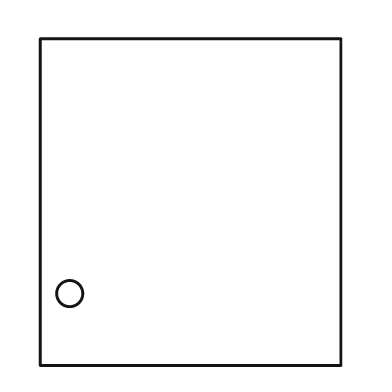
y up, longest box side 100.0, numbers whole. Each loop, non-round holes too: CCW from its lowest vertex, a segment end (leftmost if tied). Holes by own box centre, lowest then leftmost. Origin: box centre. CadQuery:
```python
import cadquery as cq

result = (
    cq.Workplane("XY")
    .moveTo(-46.0, -50.0)
    .lineTo(46.0, -50.0)
    .lineTo(46.0, 50.0)
    .lineTo(-46.0, 50.0)
    .close()
    .moveTo(-37.0, -28.0)
    .circle(4.0)
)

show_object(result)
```